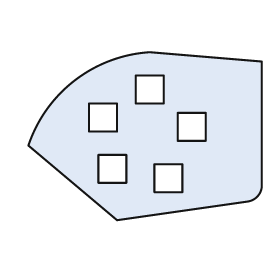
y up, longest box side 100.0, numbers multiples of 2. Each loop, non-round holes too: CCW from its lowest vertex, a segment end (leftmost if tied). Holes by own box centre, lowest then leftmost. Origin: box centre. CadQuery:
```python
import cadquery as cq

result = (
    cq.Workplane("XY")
    .moveTo(-12.0, -36.0)
    .lineTo(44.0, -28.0)
    .threePointArc((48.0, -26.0), (50.0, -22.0))
    .lineTo(50.0, 32.0)
    .lineTo(2.0, 36.0)
    .threePointArc((-30.0, 24.0), (-50.0, -4.0))
    .close()
    .moveTo(4.0, -24.0)
    .lineTo(16.0, -24.0)
    .lineTo(16.0, -12.0)
    .lineTo(4.0, -12.0)
    .close()
    .moveTo(-20.0, -20.0)
    .lineTo(-8.0, -20.0)
    .lineTo(-8.0, -8.0)
    .lineTo(-20.0, -8.0)
    .close()
    .moveTo(14.0, -2.0)
    .lineTo(26.0, -2.0)
    .lineTo(26.0, 10.0)
    .lineTo(14.0, 10.0)
    .close()
    .moveTo(-24.0, 2.0)
    .lineTo(-12.0, 2.0)
    .lineTo(-12.0, 14.0)
    .lineTo(-24.0, 14.0)
    .close()
    .moveTo(-4.0, 14.0)
    .lineTo(8.0, 14.0)
    .lineTo(8.0, 26.0)
    .lineTo(-4.0, 26.0)
    .close()
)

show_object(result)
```